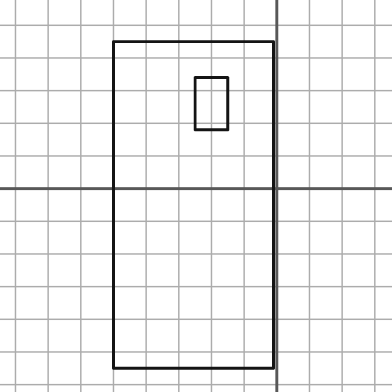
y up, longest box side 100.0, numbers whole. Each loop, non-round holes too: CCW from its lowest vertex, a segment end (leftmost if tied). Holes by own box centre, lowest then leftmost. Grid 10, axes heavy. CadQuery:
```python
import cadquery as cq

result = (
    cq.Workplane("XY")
    .moveTo(-50.0, -55.0)
    .lineTo(-1.0, -55.0)
    .lineTo(-1.0, 45.0)
    .lineTo(-50.0, 45.0)
    .close()
    .moveTo(-25.0, 18.0)
    .lineTo(-15.0, 18.0)
    .lineTo(-15.0, 34.0)
    .lineTo(-25.0, 34.0)
    .close()
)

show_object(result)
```